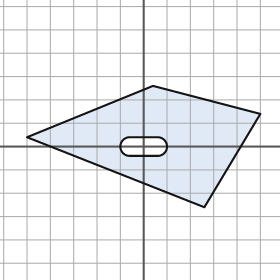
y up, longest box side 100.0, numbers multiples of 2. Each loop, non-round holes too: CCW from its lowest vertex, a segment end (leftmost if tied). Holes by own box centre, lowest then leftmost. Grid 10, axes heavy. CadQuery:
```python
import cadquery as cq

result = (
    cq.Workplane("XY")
    .moveTo(26.0, -26.0)
    .lineTo(50.0, 14.0)
    .lineTo(4.0, 26.0)
    .lineTo(-50.0, 4.0)
    .close()
    .moveTo(-6.0, -4.0)
    .lineTo(6.0, -4.0)
    .threePointArc((10.0, 0.0), (6.0, 4.0))
    .lineTo(-6.0, 4.0)
    .threePointArc((-10.0, 0.0), (-6.0, -4.0))
    .close()
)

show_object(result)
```